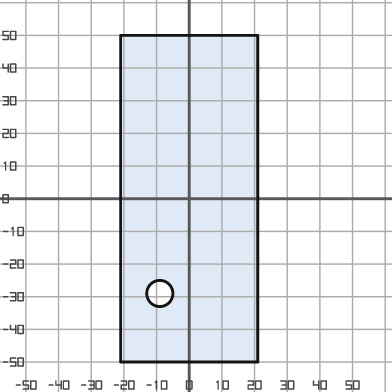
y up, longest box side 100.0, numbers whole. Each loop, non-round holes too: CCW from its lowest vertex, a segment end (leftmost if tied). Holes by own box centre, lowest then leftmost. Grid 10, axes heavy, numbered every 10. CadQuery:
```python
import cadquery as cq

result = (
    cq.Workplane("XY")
    .moveTo(-21.0, -50.0)
    .lineTo(21.0, -50.0)
    .lineTo(21.0, 50.0)
    .lineTo(-21.0, 50.0)
    .close()
    .moveTo(-9.0, -29.0)
    .circle(4.0)
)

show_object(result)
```